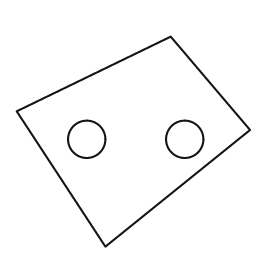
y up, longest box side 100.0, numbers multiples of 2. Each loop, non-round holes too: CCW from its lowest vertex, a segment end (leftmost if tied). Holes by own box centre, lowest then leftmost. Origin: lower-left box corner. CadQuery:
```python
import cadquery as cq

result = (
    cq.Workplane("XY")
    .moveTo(38.0, 0.0)
    .lineTo(100.0, 50.0)
    .lineTo(66.0, 90.0)
    .lineTo(0.0, 58.0)
    .close()
    .moveTo(30.0, 46.0)
    .circle(8.0)
    .moveTo(72.0, 46.0)
    .circle(8.0)
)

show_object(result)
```